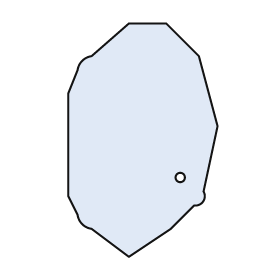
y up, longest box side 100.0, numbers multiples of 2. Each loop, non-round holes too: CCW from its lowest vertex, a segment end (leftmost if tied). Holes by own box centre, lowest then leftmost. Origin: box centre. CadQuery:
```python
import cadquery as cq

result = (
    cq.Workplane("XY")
    .moveTo(-6.0, -50.0)
    .lineTo(12.0, -38.0)
    .lineTo(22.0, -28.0)
    .threePointArc((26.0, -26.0), (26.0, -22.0))
    .lineTo(32.0, 6.0)
    .lineTo(24.0, 36.0)
    .lineTo(10.0, 50.0)
    .lineTo(-6.0, 50.0)
    .lineTo(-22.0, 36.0)
    .threePointArc((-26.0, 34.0), (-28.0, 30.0))
    .lineTo(-32.0, 20.0)
    .lineTo(-32.0, -24.0)
    .lineTo(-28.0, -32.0)
    .threePointArc((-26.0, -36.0), (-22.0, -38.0))
    .close()
    .moveTo(16.0, -16.0)
    .circle(2.0)
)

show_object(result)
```